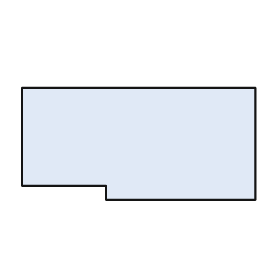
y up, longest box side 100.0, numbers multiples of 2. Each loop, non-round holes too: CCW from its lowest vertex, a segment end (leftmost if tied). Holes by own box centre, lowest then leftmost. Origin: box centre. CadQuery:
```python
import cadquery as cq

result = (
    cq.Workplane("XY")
    .moveTo(-14.0, -24.0)
    .lineTo(50.0, -24.0)
    .lineTo(50.0, 24.0)
    .lineTo(-50.0, 24.0)
    .lineTo(-50.0, -18.0)
    .lineTo(-14.0, -18.0)
    .close()
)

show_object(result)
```